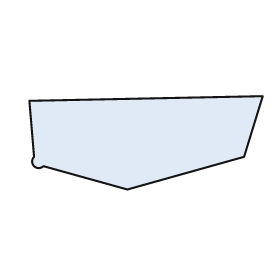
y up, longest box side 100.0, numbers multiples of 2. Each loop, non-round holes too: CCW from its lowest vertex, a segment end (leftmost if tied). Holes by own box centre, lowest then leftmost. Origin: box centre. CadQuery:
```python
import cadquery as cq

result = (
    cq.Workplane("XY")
    .moveTo(-8.0, -20.0)
    .lineTo(42.0, -6.0)
    .lineTo(50.0, 20.0)
    .lineTo(-50.0, 18.0)
    .lineTo(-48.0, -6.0)
    .threePointArc((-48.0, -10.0), (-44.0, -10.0))
    .close()
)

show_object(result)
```